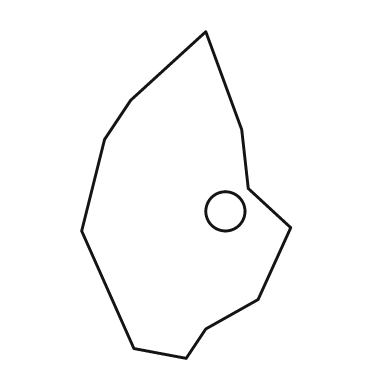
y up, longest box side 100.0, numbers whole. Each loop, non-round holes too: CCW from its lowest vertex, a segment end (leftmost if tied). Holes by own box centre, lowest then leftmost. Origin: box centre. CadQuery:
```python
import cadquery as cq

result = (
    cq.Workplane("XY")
    .moveTo(0.0, -50.0)
    .lineTo(6.0, -41.0)
    .lineTo(22.0, -32.0)
    .lineTo(32.0, -10.0)
    .lineTo(19.0, 2.0)
    .lineTo(17.0, 20.0)
    .lineTo(6.0, 50.0)
    .lineTo(-17.0, 29.0)
    .lineTo(-25.0, 17.0)
    .lineTo(-32.0, -11.0)
    .lineTo(-16.0, -47.0)
    .close()
    .moveTo(12.0, -5.0)
    .circle(6.0)
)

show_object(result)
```